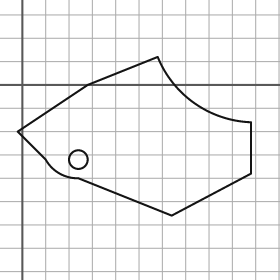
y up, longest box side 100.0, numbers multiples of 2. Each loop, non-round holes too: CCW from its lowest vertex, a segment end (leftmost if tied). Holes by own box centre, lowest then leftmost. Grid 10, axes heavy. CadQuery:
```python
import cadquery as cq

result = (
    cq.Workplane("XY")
    .moveTo(64.0, -56.0)
    .lineTo(98.0, -38.0)
    .lineTo(98.0, -16.0)
    .threePointArc((74.0, -8.0), (58.0, 12.0))
    .lineTo(28.0, 0.0)
    .lineTo(-2.0, -20.0)
    .lineTo(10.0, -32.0)
    .threePointArc((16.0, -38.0), (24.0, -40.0))
    .close()
    .moveTo(24.0, -32.0)
    .circle(4.0)
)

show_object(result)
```